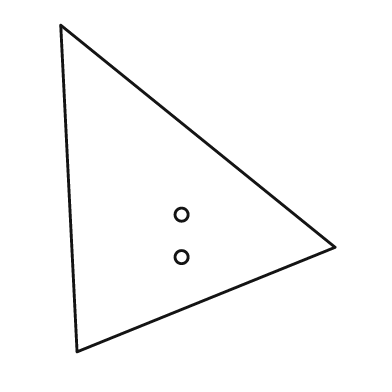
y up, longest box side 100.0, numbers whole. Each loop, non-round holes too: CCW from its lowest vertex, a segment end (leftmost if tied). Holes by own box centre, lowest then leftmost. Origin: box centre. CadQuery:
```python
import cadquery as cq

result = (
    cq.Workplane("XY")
    .moveTo(-37.0, -50.0)
    .lineTo(42.0, -18.0)
    .lineTo(-42.0, 50.0)
    .close()
    .moveTo(-5.0, -21.0)
    .circle(2.0)
    .moveTo(-5.0, -8.0)
    .circle(2.0)
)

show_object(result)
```